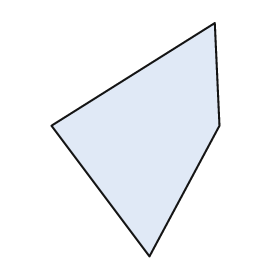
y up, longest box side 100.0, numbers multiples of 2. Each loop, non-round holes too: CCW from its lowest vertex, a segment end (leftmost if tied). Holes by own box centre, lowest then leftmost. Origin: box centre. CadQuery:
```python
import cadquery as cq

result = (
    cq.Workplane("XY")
    .moveTo(6.0, -50.0)
    .lineTo(36.0, 6.0)
    .lineTo(34.0, 50.0)
    .lineTo(-36.0, 6.0)
    .close()
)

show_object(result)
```